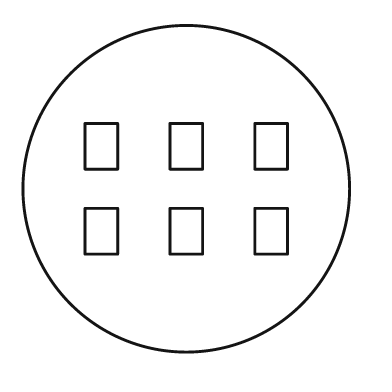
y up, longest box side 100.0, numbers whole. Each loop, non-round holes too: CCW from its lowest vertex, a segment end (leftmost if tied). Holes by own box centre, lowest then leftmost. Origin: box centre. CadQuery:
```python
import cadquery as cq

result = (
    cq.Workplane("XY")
    .moveTo(0.0, 0.0)
    .circle(50.0)
    .moveTo(-31.0, -20.0)
    .lineTo(-21.0, -20.0)
    .lineTo(-21.0, -6.0)
    .lineTo(-31.0, -6.0)
    .close()
    .moveTo(-5.0, -20.0)
    .lineTo(5.0, -20.0)
    .lineTo(5.0, -6.0)
    .lineTo(-5.0, -6.0)
    .close()
    .moveTo(21.0, -20.0)
    .lineTo(31.0, -20.0)
    .lineTo(31.0, -6.0)
    .lineTo(21.0, -6.0)
    .close()
    .moveTo(-31.0, 6.0)
    .lineTo(-21.0, 6.0)
    .lineTo(-21.0, 20.0)
    .lineTo(-31.0, 20.0)
    .close()
    .moveTo(-5.0, 6.0)
    .lineTo(5.0, 6.0)
    .lineTo(5.0, 20.0)
    .lineTo(-5.0, 20.0)
    .close()
    .moveTo(21.0, 6.0)
    .lineTo(31.0, 6.0)
    .lineTo(31.0, 20.0)
    .lineTo(21.0, 20.0)
    .close()
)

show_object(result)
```